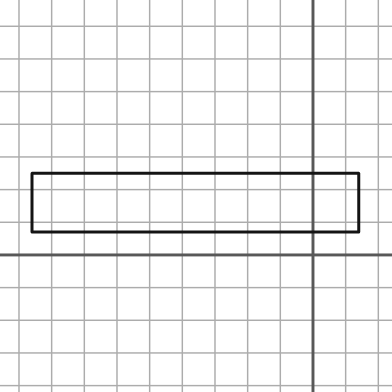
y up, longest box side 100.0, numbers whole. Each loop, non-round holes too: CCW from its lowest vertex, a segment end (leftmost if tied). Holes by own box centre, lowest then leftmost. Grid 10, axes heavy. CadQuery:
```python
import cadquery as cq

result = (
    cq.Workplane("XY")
    .moveTo(-86.0, 7.0)
    .lineTo(14.0, 7.0)
    .lineTo(14.0, 25.0)
    .lineTo(-86.0, 25.0)
    .close()
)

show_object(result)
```